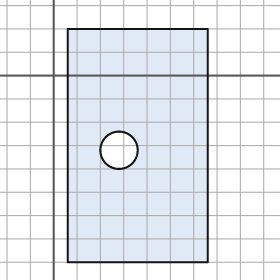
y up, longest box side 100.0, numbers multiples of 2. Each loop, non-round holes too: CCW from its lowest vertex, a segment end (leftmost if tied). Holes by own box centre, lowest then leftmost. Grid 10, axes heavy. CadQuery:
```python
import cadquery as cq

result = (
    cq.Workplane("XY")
    .moveTo(6.0, -80.0)
    .lineTo(66.0, -80.0)
    .lineTo(66.0, 20.0)
    .lineTo(6.0, 20.0)
    .close()
    .moveTo(28.0, -32.0)
    .circle(8.0)
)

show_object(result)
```